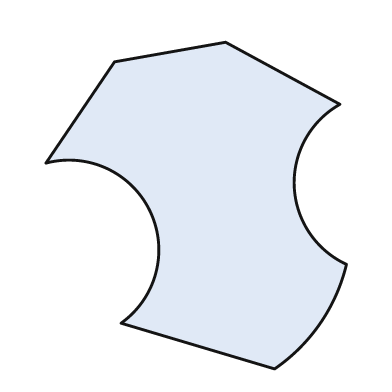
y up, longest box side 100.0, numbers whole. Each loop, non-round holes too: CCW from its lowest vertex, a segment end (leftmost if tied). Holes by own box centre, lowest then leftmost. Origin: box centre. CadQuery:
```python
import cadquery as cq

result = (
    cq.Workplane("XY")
    .moveTo(24.0, -50.0)
    .threePointArc((38.0, -36.0), (46.0, -18.0))
    .threePointArc((30.0, 6.0), (44.0, 31.0))
    .lineTo(9.0, 50.0)
    .lineTo(-25.0, 44.0)
    .lineTo(-46.0, 13.0)
    .threePointArc((-14.0, -2.0), (-23.0, -36.0))
    .close()
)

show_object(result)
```